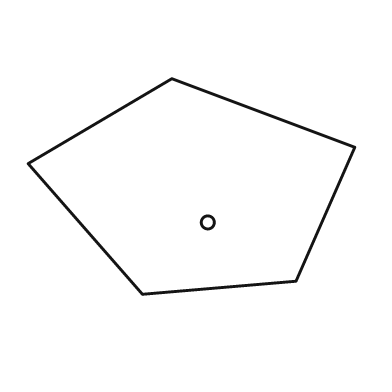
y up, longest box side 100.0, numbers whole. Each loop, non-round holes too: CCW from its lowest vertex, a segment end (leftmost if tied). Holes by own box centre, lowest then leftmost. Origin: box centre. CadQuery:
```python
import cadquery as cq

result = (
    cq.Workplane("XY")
    .moveTo(-15.0, -33.0)
    .lineTo(32.0, -29.0)
    .lineTo(50.0, 12.0)
    .lineTo(-6.0, 33.0)
    .lineTo(-50.0, 7.0)
    .close()
    .moveTo(5.0, -11.0)
    .circle(2.0)
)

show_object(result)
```